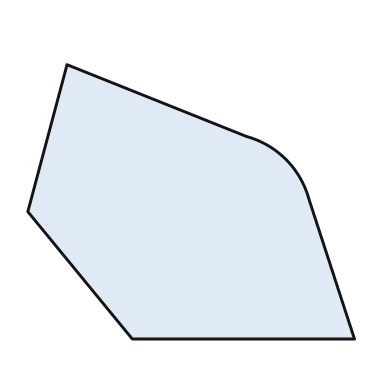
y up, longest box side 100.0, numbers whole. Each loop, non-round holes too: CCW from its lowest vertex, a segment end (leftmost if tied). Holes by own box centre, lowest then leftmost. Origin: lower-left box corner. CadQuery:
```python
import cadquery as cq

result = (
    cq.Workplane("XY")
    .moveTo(32.0, 0.0)
    .lineTo(100.0, 0.0)
    .lineTo(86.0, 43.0)
    .threePointArc((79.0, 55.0), (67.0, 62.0))
    .lineTo(12.0, 84.0)
    .lineTo(0.0, 39.0)
    .close()
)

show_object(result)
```